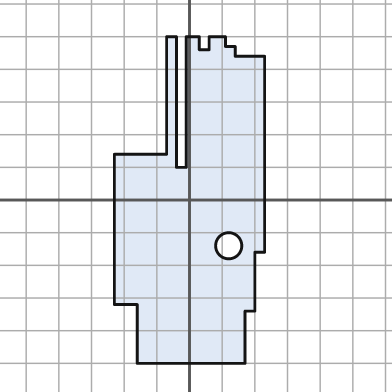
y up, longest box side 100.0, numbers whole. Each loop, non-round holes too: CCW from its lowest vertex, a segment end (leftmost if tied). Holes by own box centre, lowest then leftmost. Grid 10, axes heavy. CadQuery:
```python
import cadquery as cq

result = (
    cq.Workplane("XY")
    .moveTo(-16.0, -50.0)
    .lineTo(17.0, -50.0)
    .lineTo(17.0, -34.0)
    .lineTo(20.0, -34.0)
    .lineTo(20.0, -16.0)
    .lineTo(23.0, -16.0)
    .lineTo(23.0, 44.0)
    .lineTo(14.0, 44.0)
    .lineTo(14.0, 47.0)
    .lineTo(11.0, 47.0)
    .lineTo(11.0, 50.0)
    .lineTo(6.0, 50.0)
    .lineTo(6.0, 46.0)
    .lineTo(3.0, 46.0)
    .lineTo(3.0, 50.0)
    .lineTo(-1.0, 50.0)
    .lineTo(-1.0, 10.0)
    .lineTo(-4.0, 10.0)
    .lineTo(-4.0, 50.0)
    .lineTo(-7.0, 50.0)
    .lineTo(-7.0, 14.0)
    .lineTo(-23.0, 14.0)
    .lineTo(-23.0, -32.0)
    .lineTo(-16.0, -32.0)
    .close()
    .moveTo(12.0, -14.0)
    .circle(4.0)
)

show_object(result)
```